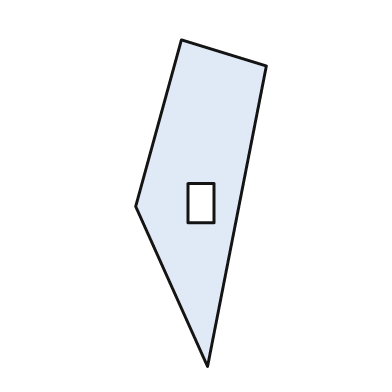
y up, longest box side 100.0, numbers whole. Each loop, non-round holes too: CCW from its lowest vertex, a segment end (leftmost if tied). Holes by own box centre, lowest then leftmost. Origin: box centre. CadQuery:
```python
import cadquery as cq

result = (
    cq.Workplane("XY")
    .moveTo(2.0, -50.0)
    .lineTo(20.0, 42.0)
    .lineTo(-6.0, 50.0)
    .lineTo(-20.0, -1.0)
    .close()
    .moveTo(-4.0, -6.0)
    .lineTo(4.0, -6.0)
    .lineTo(4.0, 6.0)
    .lineTo(-4.0, 6.0)
    .close()
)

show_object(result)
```